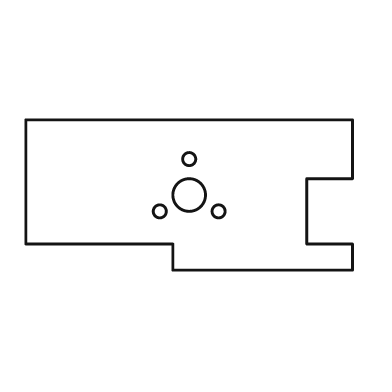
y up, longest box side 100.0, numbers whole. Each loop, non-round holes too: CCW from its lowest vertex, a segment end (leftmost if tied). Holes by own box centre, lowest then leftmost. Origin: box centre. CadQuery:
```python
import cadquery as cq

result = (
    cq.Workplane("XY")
    .moveTo(-5.0, -23.0)
    .lineTo(50.0, -23.0)
    .lineTo(50.0, -15.0)
    .lineTo(36.0, -15.0)
    .lineTo(36.0, 5.0)
    .lineTo(50.0, 5.0)
    .lineTo(50.0, 23.0)
    .lineTo(-50.0, 23.0)
    .lineTo(-50.0, -15.0)
    .lineTo(-5.0, -15.0)
    .close()
    .moveTo(-9.0, -5.0)
    .circle(2.0)
    .moveTo(9.0, -5.0)
    .circle(2.0)
    .moveTo(0.0, 0.0)
    .circle(5.0)
    .moveTo(0.0, 11.0)
    .circle(2.0)
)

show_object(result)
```